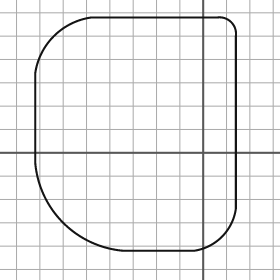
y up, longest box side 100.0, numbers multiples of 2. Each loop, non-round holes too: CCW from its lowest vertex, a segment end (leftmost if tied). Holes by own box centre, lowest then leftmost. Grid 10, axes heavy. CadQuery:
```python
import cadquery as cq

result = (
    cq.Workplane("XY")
    .moveTo(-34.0, -42.0)
    .lineTo(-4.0, -42.0)
    .threePointArc((8.0, -36.0), (14.0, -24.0))
    .lineTo(14.0, 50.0)
    .threePointArc((12.0, 56.0), (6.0, 58.0))
    .lineTo(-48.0, 58.0)
    .threePointArc((-64.0, 50.0), (-72.0, 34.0))
    .lineTo(-72.0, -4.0)
    .threePointArc((-60.0, -30.0), (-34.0, -42.0))
    .close()
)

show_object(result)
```